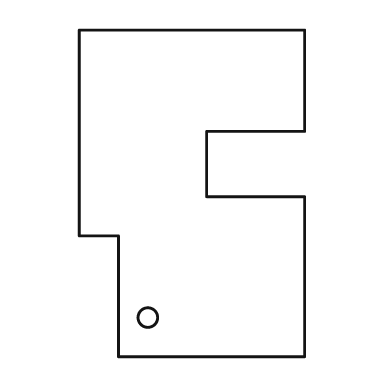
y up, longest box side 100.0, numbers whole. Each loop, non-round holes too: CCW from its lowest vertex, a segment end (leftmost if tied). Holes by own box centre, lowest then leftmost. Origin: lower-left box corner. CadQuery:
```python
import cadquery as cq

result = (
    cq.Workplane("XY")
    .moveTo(12.0, 0.0)
    .lineTo(69.0, 0.0)
    .lineTo(69.0, 49.0)
    .lineTo(39.0, 49.0)
    .lineTo(39.0, 69.0)
    .lineTo(69.0, 69.0)
    .lineTo(69.0, 100.0)
    .lineTo(0.0, 100.0)
    .lineTo(0.0, 37.0)
    .lineTo(12.0, 37.0)
    .close()
    .moveTo(21.0, 12.0)
    .circle(3.0)
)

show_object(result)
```